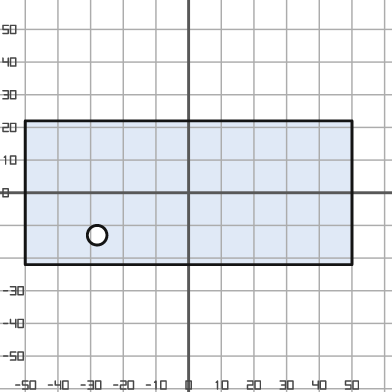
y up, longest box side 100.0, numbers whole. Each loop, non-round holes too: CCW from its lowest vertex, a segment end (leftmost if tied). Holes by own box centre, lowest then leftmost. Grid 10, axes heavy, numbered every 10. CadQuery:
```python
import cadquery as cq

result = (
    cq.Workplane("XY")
    .moveTo(-50.0, -22.0)
    .lineTo(50.0, -22.0)
    .lineTo(50.0, 22.0)
    .lineTo(-50.0, 22.0)
    .close()
    .moveTo(-28.0, -13.0)
    .circle(3.0)
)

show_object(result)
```